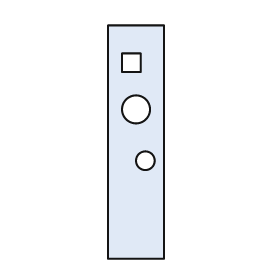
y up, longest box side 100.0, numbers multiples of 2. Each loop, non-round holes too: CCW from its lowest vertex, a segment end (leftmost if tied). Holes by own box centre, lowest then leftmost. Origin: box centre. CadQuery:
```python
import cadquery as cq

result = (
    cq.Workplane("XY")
    .moveTo(-12.0, -50.0)
    .lineTo(12.0, -50.0)
    .lineTo(12.0, 50.0)
    .lineTo(-12.0, 50.0)
    .close()
    .moveTo(4.0, -8.0)
    .circle(4.0)
    .moveTo(0.0, 14.0)
    .circle(6.0)
    .moveTo(-6.0, 30.0)
    .lineTo(2.0, 30.0)
    .lineTo(2.0, 38.0)
    .lineTo(-6.0, 38.0)
    .close()
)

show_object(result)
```